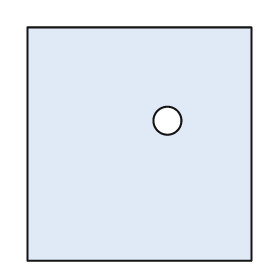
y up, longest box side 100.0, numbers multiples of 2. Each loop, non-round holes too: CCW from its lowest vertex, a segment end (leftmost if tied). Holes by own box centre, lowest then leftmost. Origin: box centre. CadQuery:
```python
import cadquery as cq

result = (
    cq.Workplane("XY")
    .moveTo(-48.0, -50.0)
    .lineTo(48.0, -50.0)
    .lineTo(48.0, 50.0)
    .lineTo(-48.0, 50.0)
    .close()
    .moveTo(12.0, 10.0)
    .circle(6.0)
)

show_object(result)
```